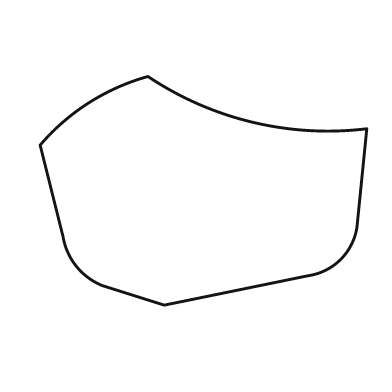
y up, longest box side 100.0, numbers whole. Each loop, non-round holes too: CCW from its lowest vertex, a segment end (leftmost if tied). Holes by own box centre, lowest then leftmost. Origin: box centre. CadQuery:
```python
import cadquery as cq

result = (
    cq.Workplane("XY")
    .moveTo(-12.0, -35.0)
    .lineTo(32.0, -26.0)
    .threePointArc((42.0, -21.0), (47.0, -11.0))
    .lineTo(50.0, 19.0)
    .threePointArc((15.0, 21.0), (-17.0, 35.0))
    .threePointArc((-35.0, 27.0), (-50.0, 14.0))
    .lineTo(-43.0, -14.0)
    .threePointArc((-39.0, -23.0), (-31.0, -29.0))
    .close()
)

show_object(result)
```